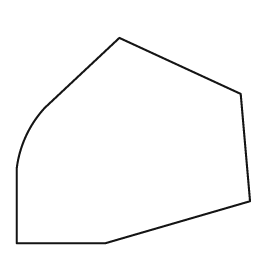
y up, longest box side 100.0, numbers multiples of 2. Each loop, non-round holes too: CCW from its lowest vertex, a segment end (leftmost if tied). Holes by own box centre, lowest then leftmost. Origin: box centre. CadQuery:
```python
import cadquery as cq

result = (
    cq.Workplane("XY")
    .moveTo(-50.0, -44.0)
    .lineTo(-12.0, -44.0)
    .lineTo(50.0, -26.0)
    .lineTo(46.0, 20.0)
    .lineTo(-6.0, 44.0)
    .lineTo(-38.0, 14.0)
    .threePointArc((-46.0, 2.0), (-50.0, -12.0))
    .close()
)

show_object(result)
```